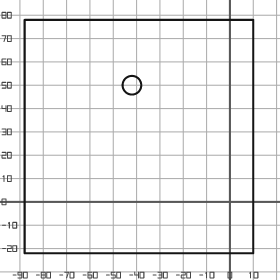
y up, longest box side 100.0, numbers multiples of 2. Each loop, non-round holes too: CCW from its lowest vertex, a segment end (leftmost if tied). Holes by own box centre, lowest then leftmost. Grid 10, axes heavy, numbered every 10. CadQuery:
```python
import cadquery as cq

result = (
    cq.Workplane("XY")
    .moveTo(-88.0, -22.0)
    .lineTo(10.0, -22.0)
    .lineTo(10.0, 78.0)
    .lineTo(-88.0, 78.0)
    .close()
    .moveTo(-42.0, 50.0)
    .circle(4.0)
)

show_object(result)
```